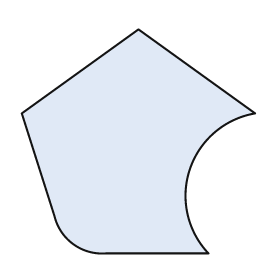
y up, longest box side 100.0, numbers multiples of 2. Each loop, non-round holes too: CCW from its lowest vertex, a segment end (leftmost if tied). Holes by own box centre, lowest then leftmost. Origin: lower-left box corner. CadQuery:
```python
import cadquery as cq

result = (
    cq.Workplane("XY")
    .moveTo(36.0, 0.0)
    .lineTo(80.0, 0.0)
    .threePointArc((72.0, 36.0), (100.0, 60.0))
    .lineTo(50.0, 96.0)
    .lineTo(0.0, 60.0)
    .lineTo(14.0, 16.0)
    .threePointArc((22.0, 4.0), (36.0, 0.0))
    .close()
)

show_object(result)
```